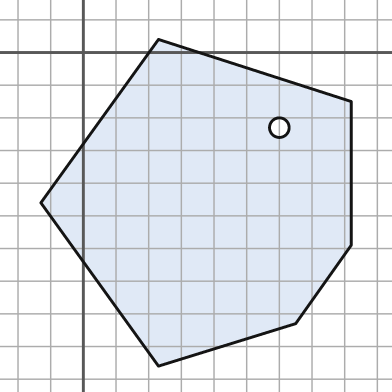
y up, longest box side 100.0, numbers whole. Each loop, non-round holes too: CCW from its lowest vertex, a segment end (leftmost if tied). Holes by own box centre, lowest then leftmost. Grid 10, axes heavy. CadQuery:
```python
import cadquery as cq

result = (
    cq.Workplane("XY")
    .moveTo(23.0, -96.0)
    .lineTo(65.0, -83.0)
    .lineTo(82.0, -59.0)
    .lineTo(82.0, -15.0)
    .lineTo(23.0, 4.0)
    .lineTo(-13.0, -46.0)
    .close()
    .moveTo(60.0, -23.0)
    .circle(3.0)
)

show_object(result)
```